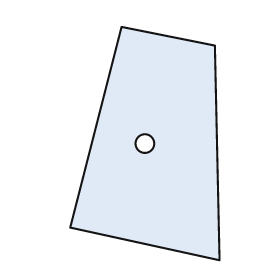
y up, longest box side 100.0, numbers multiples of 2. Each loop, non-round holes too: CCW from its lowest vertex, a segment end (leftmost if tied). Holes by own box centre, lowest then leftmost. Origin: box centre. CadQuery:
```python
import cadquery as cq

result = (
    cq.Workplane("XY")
    .moveTo(32.0, -50.0)
    .lineTo(30.0, 42.0)
    .lineTo(-10.0, 50.0)
    .lineTo(-32.0, -36.0)
    .close()
    .moveTo(0.0, 0.0)
    .circle(4.0)
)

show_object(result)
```